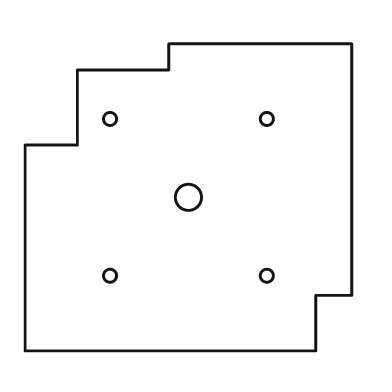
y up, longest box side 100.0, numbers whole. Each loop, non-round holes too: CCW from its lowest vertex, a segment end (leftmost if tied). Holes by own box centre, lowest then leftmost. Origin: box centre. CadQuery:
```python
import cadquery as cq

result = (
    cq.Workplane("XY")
    .moveTo(-50.0, -47.0)
    .lineTo(39.0, -47.0)
    .lineTo(39.0, -30.0)
    .lineTo(50.0, -30.0)
    .lineTo(50.0, 47.0)
    .lineTo(-6.0, 47.0)
    .lineTo(-6.0, 39.0)
    .lineTo(-34.0, 39.0)
    .lineTo(-34.0, 16.0)
    .lineTo(-50.0, 16.0)
    .close()
    .moveTo(-24.0, -24.0)
    .circle(2.0)
    .moveTo(24.0, -24.0)
    .circle(2.0)
    .moveTo(0.0, 0.0)
    .circle(4.0)
    .moveTo(-24.0, 24.0)
    .circle(2.0)
    .moveTo(24.0, 24.0)
    .circle(2.0)
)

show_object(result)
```